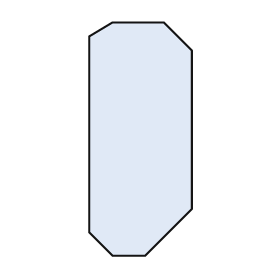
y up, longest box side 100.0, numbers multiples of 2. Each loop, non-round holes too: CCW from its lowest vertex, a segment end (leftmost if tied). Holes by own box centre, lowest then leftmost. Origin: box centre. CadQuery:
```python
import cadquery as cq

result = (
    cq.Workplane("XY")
    .moveTo(-12.0, -50.0)
    .lineTo(2.0, -50.0)
    .lineTo(22.0, -30.0)
    .lineTo(22.0, 38.0)
    .lineTo(10.0, 50.0)
    .lineTo(-12.0, 50.0)
    .lineTo(-22.0, 44.0)
    .lineTo(-22.0, -40.0)
    .close()
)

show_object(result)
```